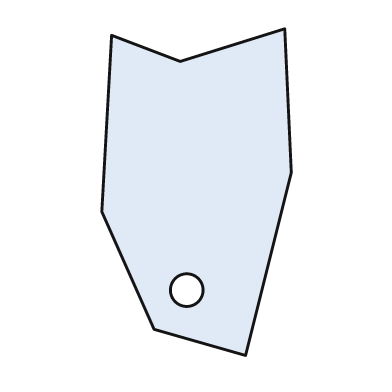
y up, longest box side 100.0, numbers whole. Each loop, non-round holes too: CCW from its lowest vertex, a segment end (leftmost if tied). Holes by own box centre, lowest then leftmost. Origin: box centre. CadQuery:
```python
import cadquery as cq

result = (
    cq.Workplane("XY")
    .moveTo(15.0, -50.0)
    .lineTo(29.0, 6.0)
    .lineTo(27.0, 50.0)
    .lineTo(-5.0, 40.0)
    .lineTo(-26.0, 48.0)
    .lineTo(-29.0, -6.0)
    .lineTo(-13.0, -42.0)
    .close()
    .moveTo(-3.0, -30.0)
    .circle(5.0)
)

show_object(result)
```